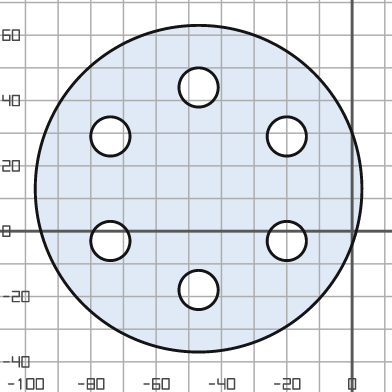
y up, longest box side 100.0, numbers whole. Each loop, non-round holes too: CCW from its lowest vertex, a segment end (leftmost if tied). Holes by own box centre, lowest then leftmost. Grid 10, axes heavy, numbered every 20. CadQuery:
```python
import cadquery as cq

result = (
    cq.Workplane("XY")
    .moveTo(-47.0, 13.0)
    .circle(50.0)
    .moveTo(-47.0, -18.0)
    .circle(6.0)
    .moveTo(-74.0, -3.0)
    .circle(6.0)
    .moveTo(-20.0, -3.0)
    .circle(6.0)
    .moveTo(-74.0, 29.0)
    .circle(6.0)
    .moveTo(-20.0, 29.0)
    .circle(6.0)
    .moveTo(-47.0, 44.0)
    .circle(6.0)
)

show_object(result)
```